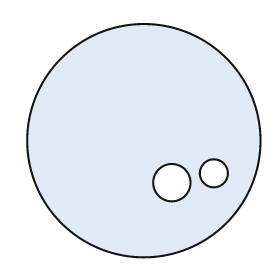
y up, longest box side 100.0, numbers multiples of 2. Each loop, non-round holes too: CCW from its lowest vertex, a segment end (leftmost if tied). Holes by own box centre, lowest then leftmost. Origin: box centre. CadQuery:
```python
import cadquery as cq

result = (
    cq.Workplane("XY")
    .moveTo(0.0, 0.0)
    .circle(50.0)
    .moveTo(12.0, -18.0)
    .circle(8.0)
    .moveTo(30.0, -14.0)
    .circle(6.0)
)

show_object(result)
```